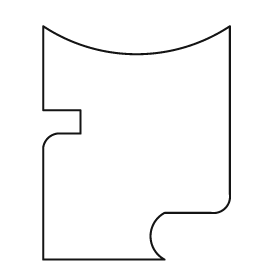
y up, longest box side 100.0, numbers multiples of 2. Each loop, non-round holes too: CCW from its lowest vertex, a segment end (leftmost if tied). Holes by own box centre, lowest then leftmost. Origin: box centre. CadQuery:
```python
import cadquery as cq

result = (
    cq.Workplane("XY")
    .moveTo(-40.0, -50.0)
    .lineTo(12.0, -50.0)
    .threePointArc((6.0, -40.0), (12.0, -30.0))
    .lineTo(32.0, -30.0)
    .threePointArc((38.0, -28.0), (40.0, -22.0))
    .lineTo(40.0, 50.0)
    .threePointArc((0.0, 38.0), (-40.0, 50.0))
    .lineTo(-40.0, 14.0)
    .lineTo(-24.0, 14.0)
    .lineTo(-24.0, 4.0)
    .lineTo(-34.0, 4.0)
    .threePointArc((-38.0, 2.0), (-40.0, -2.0))
    .close()
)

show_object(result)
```